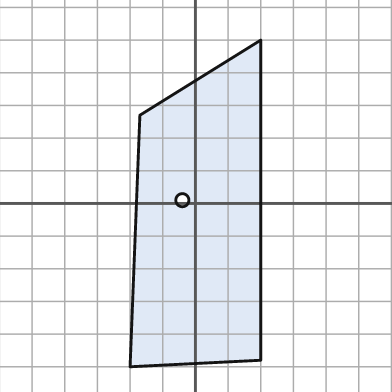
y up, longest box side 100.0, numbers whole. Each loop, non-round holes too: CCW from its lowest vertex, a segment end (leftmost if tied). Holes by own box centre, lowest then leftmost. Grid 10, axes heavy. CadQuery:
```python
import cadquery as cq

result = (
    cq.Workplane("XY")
    .moveTo(-20.0, -50.0)
    .lineTo(20.0, -48.0)
    .lineTo(20.0, 50.0)
    .lineTo(-17.0, 27.0)
    .close()
    .moveTo(-4.0, 1.0)
    .circle(2.0)
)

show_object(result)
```